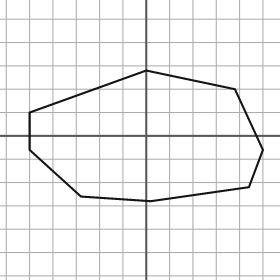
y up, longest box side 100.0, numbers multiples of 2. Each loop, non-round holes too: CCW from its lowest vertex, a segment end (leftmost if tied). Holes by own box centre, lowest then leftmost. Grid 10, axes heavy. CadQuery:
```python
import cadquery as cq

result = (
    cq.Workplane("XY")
    .moveTo(2.0, -28.0)
    .lineTo(44.0, -22.0)
    .lineTo(50.0, -6.0)
    .lineTo(38.0, 20.0)
    .lineTo(0.0, 28.0)
    .lineTo(-50.0, 10.0)
    .lineTo(-50.0, -6.0)
    .lineTo(-28.0, -26.0)
    .close()
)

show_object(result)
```